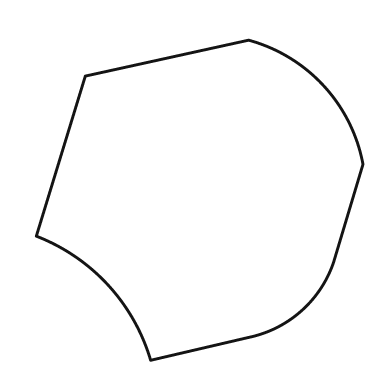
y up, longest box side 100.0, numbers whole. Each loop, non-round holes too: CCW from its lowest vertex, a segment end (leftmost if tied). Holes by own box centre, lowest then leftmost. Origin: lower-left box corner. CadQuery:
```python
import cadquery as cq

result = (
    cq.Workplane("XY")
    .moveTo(35.0, 0.0)
    .lineTo(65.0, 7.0)
    .threePointArc((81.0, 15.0), (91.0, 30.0))
    .lineTo(100.0, 60.0)
    .threePointArc((88.0, 84.0), (65.0, 98.0))
    .lineTo(15.0, 87.0)
    .lineTo(0.0, 38.0)
    .threePointArc((22.0, 23.0), (35.0, 0.0))
    .close()
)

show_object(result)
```